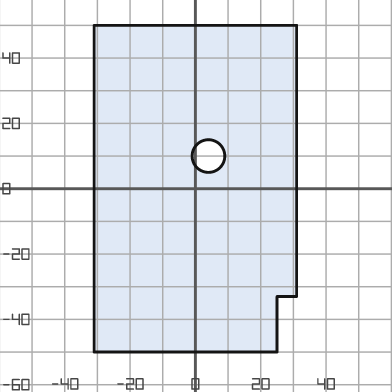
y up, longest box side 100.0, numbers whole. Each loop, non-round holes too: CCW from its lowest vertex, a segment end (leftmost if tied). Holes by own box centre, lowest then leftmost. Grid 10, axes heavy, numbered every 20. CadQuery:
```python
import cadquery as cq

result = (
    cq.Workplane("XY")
    .moveTo(-31.0, -50.0)
    .lineTo(25.0, -50.0)
    .lineTo(25.0, -33.0)
    .lineTo(31.0, -33.0)
    .lineTo(31.0, 50.0)
    .lineTo(-31.0, 50.0)
    .close()
    .moveTo(4.0, 10.0)
    .circle(5.0)
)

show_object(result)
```